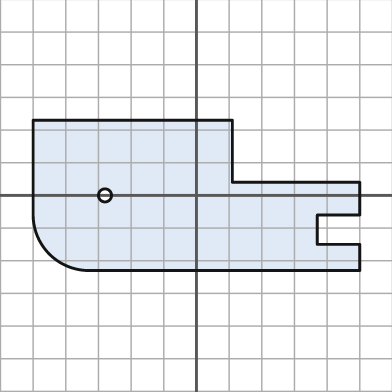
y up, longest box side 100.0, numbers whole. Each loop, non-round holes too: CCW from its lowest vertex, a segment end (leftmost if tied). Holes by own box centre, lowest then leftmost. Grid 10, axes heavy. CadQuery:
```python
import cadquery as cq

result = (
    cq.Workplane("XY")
    .moveTo(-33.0, -23.0)
    .lineTo(50.0, -23.0)
    .lineTo(50.0, -15.0)
    .lineTo(37.0, -15.0)
    .lineTo(37.0, -6.0)
    .lineTo(50.0, -6.0)
    .lineTo(50.0, 4.0)
    .lineTo(11.0, 4.0)
    .lineTo(11.0, 23.0)
    .lineTo(-50.0, 23.0)
    .lineTo(-50.0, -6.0)
    .threePointArc((-45.0, -18.0), (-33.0, -23.0))
    .close()
    .moveTo(-28.0, 0.0)
    .circle(2.0)
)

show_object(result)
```